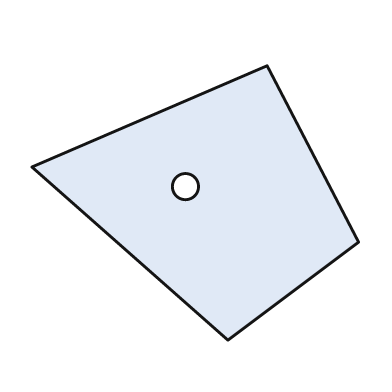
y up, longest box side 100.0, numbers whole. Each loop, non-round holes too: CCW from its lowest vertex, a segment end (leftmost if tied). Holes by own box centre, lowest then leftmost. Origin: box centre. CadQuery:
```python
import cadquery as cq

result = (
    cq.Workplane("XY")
    .moveTo(10.0, -42.0)
    .lineTo(50.0, -12.0)
    .lineTo(22.0, 42.0)
    .lineTo(-50.0, 11.0)
    .close()
    .moveTo(-3.0, 5.0)
    .circle(4.0)
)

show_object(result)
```